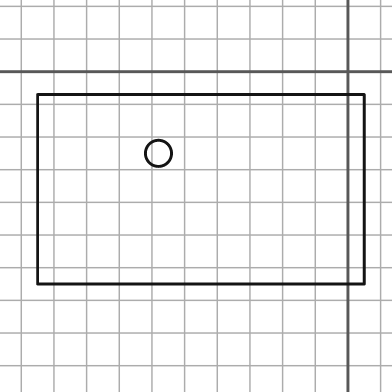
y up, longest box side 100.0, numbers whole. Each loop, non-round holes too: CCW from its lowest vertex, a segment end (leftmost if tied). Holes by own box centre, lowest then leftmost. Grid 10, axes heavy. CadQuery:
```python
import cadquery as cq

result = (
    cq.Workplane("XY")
    .moveTo(-95.0, -65.0)
    .lineTo(5.0, -65.0)
    .lineTo(5.0, -7.0)
    .lineTo(-95.0, -7.0)
    .close()
    .moveTo(-58.0, -25.0)
    .circle(4.0)
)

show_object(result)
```